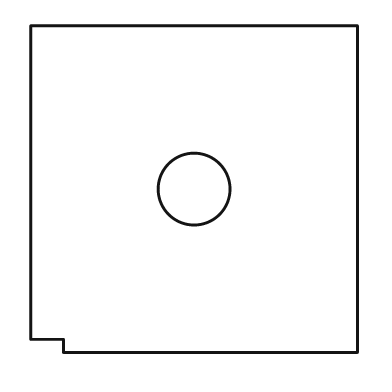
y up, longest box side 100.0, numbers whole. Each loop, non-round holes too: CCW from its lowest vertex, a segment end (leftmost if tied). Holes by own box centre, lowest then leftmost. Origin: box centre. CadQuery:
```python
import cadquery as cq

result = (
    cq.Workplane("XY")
    .moveTo(-40.0, -50.0)
    .lineTo(50.0, -50.0)
    .lineTo(50.0, 50.0)
    .lineTo(-50.0, 50.0)
    .lineTo(-50.0, -46.0)
    .lineTo(-40.0, -46.0)
    .close()
    .moveTo(0.0, 0.0)
    .circle(11.0)
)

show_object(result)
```